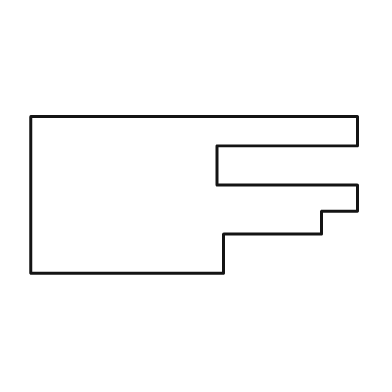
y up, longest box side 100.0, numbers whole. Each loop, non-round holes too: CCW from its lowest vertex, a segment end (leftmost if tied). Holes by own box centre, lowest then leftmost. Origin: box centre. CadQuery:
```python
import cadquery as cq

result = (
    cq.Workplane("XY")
    .moveTo(-50.0, -24.0)
    .lineTo(9.0, -24.0)
    .lineTo(9.0, -12.0)
    .lineTo(39.0, -12.0)
    .lineTo(39.0, -5.0)
    .lineTo(50.0, -5.0)
    .lineTo(50.0, 3.0)
    .lineTo(7.0, 3.0)
    .lineTo(7.0, 15.0)
    .lineTo(50.0, 15.0)
    .lineTo(50.0, 24.0)
    .lineTo(-50.0, 24.0)
    .close()
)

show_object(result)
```